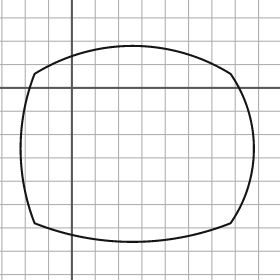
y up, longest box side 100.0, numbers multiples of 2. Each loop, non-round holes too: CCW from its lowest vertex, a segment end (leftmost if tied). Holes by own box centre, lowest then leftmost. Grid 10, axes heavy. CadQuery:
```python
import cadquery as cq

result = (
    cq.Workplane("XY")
    .moveTo(-16.0, -58.0)
    .threePointArc((26.0, -66.0), (68.0, -58.0))
    .threePointArc((78.0, -26.0), (68.0, 6.0))
    .threePointArc((26.0, 18.0), (-16.0, 6.0))
    .threePointArc((-22.0, -26.0), (-16.0, -58.0))
    .close()
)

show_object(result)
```